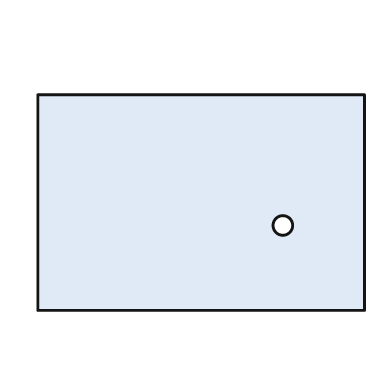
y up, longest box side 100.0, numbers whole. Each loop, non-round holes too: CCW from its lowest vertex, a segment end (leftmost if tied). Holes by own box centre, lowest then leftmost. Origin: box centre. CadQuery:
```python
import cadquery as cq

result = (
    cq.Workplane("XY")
    .moveTo(-50.0, -33.0)
    .lineTo(50.0, -33.0)
    .lineTo(50.0, 33.0)
    .lineTo(-50.0, 33.0)
    .close()
    .moveTo(25.0, -7.0)
    .circle(3.0)
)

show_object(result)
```